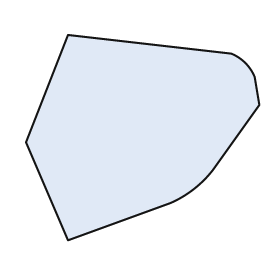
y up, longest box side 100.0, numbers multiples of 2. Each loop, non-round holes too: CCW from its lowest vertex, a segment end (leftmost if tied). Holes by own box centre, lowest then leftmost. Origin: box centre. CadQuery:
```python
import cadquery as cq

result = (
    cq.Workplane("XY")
    .moveTo(-32.0, -44.0)
    .lineTo(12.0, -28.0)
    .threePointArc((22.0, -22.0), (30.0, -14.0))
    .lineTo(50.0, 14.0)
    .lineTo(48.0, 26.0)
    .threePointArc((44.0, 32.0), (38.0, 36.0))
    .lineTo(-32.0, 44.0)
    .lineTo(-50.0, -2.0)
    .close()
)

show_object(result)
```